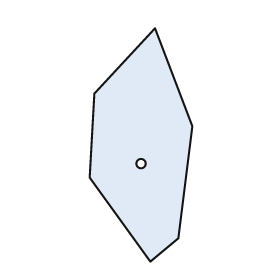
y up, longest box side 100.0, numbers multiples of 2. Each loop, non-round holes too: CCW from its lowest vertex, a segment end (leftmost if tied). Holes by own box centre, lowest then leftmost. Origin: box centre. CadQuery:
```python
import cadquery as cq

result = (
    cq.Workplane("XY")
    .moveTo(4.0, -50.0)
    .lineTo(16.0, -40.0)
    .lineTo(22.0, 8.0)
    .lineTo(6.0, 50.0)
    .lineTo(-20.0, 22.0)
    .lineTo(-22.0, -14.0)
    .close()
    .moveTo(0.0, -8.0)
    .circle(2.0)
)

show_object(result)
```